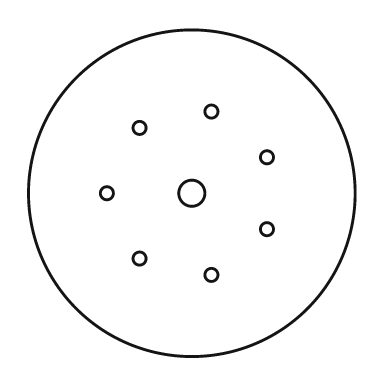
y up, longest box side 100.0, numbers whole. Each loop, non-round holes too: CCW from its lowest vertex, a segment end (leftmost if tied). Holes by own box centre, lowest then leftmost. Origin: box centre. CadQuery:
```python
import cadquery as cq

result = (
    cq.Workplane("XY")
    .moveTo(0.0, 0.0)
    .circle(50.0)
    .moveTo(6.0, -25.0)
    .circle(2.0)
    .moveTo(-16.0, -20.0)
    .circle(2.0)
    .moveTo(23.0, -11.0)
    .circle(2.0)
    .moveTo(-26.0, 0.0)
    .circle(2.0)
    .moveTo(0.0, 0.0)
    .circle(4.0)
    .moveTo(23.0, 11.0)
    .circle(2.0)
    .moveTo(-16.0, 20.0)
    .circle(2.0)
    .moveTo(6.0, 25.0)
    .circle(2.0)
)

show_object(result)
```